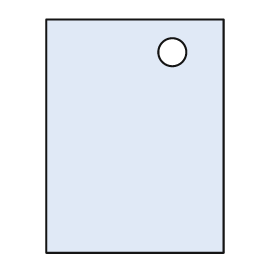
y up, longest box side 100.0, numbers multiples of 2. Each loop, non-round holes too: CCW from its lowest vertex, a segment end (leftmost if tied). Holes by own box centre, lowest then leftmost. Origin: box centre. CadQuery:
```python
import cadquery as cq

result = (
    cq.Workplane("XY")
    .moveTo(-38.0, -50.0)
    .lineTo(38.0, -50.0)
    .lineTo(38.0, 50.0)
    .lineTo(-38.0, 50.0)
    .close()
    .moveTo(16.0, 36.0)
    .circle(6.0)
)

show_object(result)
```